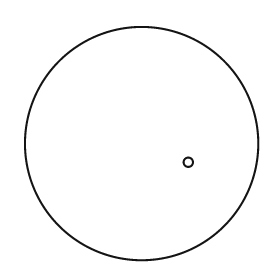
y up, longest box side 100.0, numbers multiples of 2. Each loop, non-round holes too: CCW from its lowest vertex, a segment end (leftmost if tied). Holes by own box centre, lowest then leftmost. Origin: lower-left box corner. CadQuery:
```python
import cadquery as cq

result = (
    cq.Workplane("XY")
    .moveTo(50.0, 50.0)
    .circle(50.0)
    .moveTo(70.0, 42.0)
    .circle(2.0)
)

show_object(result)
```